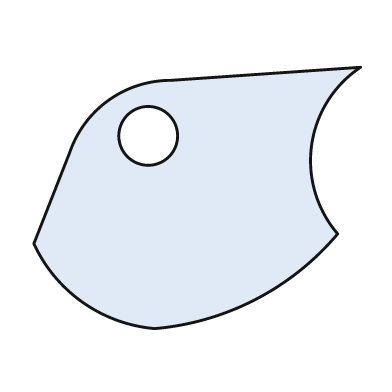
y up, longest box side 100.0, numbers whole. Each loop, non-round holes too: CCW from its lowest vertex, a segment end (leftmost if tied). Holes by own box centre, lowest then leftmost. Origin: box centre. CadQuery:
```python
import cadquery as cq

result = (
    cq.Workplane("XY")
    .moveTo(-13.0, -40.0)
    .threePointArc((18.0, -31.0), (43.0, -11.0))
    .threePointArc((35.0, 16.0), (50.0, 40.0))
    .lineTo(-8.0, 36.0)
    .threePointArc((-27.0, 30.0), (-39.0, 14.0))
    .lineTo(-50.0, -14.0)
    .threePointArc((-35.0, -32.0), (-13.0, -40.0))
    .close()
    .moveTo(-15.0, 19.0)
    .circle(9.0)
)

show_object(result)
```